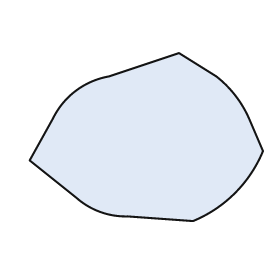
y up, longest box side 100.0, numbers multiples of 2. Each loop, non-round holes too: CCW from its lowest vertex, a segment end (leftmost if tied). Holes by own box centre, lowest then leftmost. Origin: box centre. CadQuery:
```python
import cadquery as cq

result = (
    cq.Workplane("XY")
    .moveTo(20.0, -36.0)
    .threePointArc((38.0, -24.0), (50.0, -6.0))
    .lineTo(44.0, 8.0)
    .threePointArc((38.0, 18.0), (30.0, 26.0))
    .lineTo(14.0, 36.0)
    .lineTo(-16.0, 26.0)
    .threePointArc((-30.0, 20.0), (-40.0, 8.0))
    .lineTo(-50.0, -10.0)
    .lineTo(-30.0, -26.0)
    .threePointArc((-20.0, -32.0), (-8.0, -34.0))
    .close()
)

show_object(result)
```